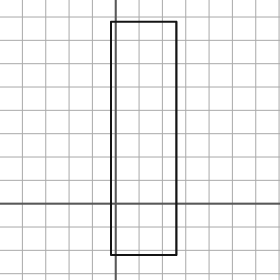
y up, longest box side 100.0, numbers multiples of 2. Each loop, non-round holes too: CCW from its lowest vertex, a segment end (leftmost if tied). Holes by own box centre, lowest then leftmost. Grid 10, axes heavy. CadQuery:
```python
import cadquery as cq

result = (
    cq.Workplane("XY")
    .moveTo(-2.0, -22.0)
    .lineTo(26.0, -22.0)
    .lineTo(26.0, 78.0)
    .lineTo(-2.0, 78.0)
    .close()
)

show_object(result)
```